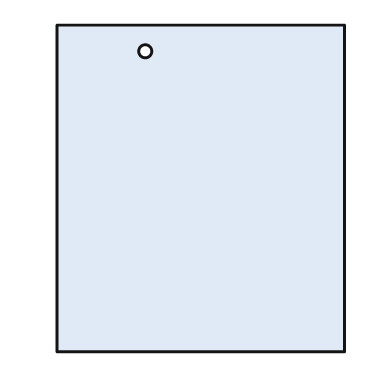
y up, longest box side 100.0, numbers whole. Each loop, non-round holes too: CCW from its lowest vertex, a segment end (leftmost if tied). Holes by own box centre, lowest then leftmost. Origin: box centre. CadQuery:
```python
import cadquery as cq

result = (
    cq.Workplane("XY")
    .moveTo(-44.0, -50.0)
    .lineTo(44.0, -50.0)
    .lineTo(44.0, 50.0)
    .lineTo(-44.0, 50.0)
    .close()
    .moveTo(-17.0, 42.0)
    .circle(2.0)
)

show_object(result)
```